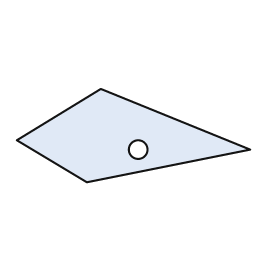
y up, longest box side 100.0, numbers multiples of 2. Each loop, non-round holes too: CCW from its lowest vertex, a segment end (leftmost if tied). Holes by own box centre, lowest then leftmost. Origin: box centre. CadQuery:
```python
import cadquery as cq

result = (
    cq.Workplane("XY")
    .moveTo(-20.0, -20.0)
    .lineTo(50.0, -6.0)
    .lineTo(-14.0, 20.0)
    .lineTo(-50.0, -2.0)
    .close()
    .moveTo(2.0, -6.0)
    .circle(4.0)
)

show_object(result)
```